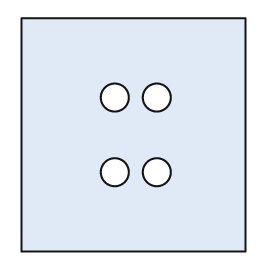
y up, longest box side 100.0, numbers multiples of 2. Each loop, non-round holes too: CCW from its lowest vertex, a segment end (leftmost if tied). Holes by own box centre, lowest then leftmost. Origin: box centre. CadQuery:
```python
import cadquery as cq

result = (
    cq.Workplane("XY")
    .moveTo(-48.0, -50.0)
    .lineTo(48.0, -50.0)
    .lineTo(48.0, 50.0)
    .lineTo(-48.0, 50.0)
    .close()
    .moveTo(-8.0, -16.0)
    .circle(6.0)
    .moveTo(10.0, -16.0)
    .circle(6.0)
    .moveTo(-8.0, 16.0)
    .circle(6.0)
    .moveTo(10.0, 16.0)
    .circle(6.0)
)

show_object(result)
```